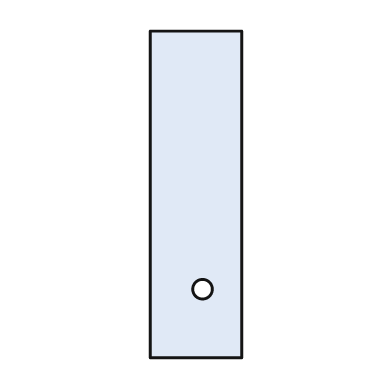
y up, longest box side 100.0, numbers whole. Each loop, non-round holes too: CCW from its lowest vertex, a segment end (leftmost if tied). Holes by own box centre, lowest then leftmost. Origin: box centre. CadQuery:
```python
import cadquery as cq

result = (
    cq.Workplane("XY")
    .moveTo(-14.0, -50.0)
    .lineTo(14.0, -50.0)
    .lineTo(14.0, 50.0)
    .lineTo(-14.0, 50.0)
    .close()
    .moveTo(2.0, -29.0)
    .circle(3.0)
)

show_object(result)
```